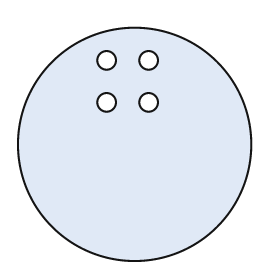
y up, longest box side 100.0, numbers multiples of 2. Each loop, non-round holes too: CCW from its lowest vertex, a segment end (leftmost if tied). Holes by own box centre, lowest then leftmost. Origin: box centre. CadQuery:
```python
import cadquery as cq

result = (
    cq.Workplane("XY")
    .moveTo(0.0, 0.0)
    .circle(50.0)
    .moveTo(-12.0, 18.0)
    .circle(4.0)
    .moveTo(6.0, 18.0)
    .circle(4.0)
    .moveTo(-12.0, 36.0)
    .circle(4.0)
    .moveTo(6.0, 36.0)
    .circle(4.0)
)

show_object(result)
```